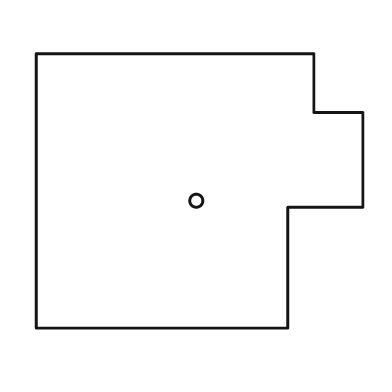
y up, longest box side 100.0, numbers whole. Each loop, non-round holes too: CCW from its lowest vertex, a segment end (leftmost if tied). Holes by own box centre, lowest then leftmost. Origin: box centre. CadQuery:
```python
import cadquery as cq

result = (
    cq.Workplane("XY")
    .moveTo(-50.0, -42.0)
    .lineTo(27.0, -42.0)
    .lineTo(27.0, -5.0)
    .lineTo(50.0, -5.0)
    .lineTo(50.0, 24.0)
    .lineTo(35.0, 24.0)
    .lineTo(35.0, 42.0)
    .lineTo(-50.0, 42.0)
    .close()
    .moveTo(-1.0, -3.0)
    .circle(2.0)
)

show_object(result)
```